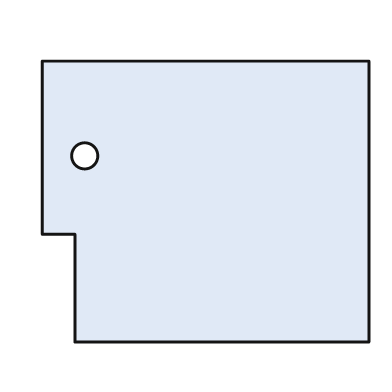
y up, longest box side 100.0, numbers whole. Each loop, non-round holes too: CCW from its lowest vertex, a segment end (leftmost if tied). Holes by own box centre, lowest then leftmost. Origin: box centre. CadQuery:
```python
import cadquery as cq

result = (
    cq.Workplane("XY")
    .moveTo(-40.0, -43.0)
    .lineTo(50.0, -43.0)
    .lineTo(50.0, 43.0)
    .lineTo(-50.0, 43.0)
    .lineTo(-50.0, -10.0)
    .lineTo(-40.0, -10.0)
    .close()
    .moveTo(-37.0, 14.0)
    .circle(4.0)
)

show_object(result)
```